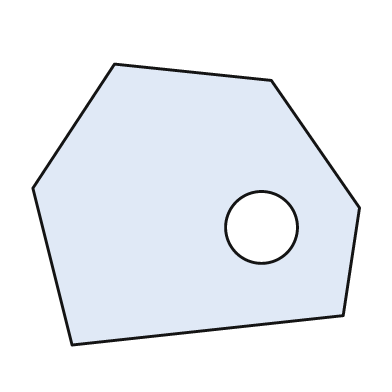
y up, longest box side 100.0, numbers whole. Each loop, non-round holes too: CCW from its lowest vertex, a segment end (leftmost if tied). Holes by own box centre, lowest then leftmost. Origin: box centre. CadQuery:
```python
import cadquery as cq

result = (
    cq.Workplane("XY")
    .moveTo(-38.0, -43.0)
    .lineTo(45.0, -34.0)
    .lineTo(50.0, -1.0)
    .lineTo(23.0, 38.0)
    .lineTo(-25.0, 43.0)
    .lineTo(-50.0, 5.0)
    .close()
    .moveTo(20.0, -7.0)
    .circle(11.0)
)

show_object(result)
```